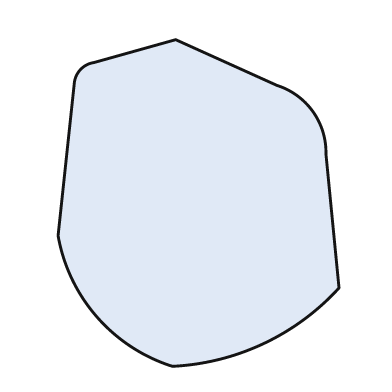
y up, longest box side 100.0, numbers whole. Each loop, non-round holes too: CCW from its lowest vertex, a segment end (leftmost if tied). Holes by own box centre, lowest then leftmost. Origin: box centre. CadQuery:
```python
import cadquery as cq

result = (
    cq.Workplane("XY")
    .moveTo(-8.0, -50.0)
    .threePointArc((20.0, -43.0), (43.0, -26.0))
    .lineTo(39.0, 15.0)
    .threePointArc((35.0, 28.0), (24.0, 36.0))
    .lineTo(-7.0, 50.0)
    .lineTo(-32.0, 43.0)
    .threePointArc((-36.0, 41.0), (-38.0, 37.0))
    .lineTo(-43.0, -10.0)
    .threePointArc((-31.0, -35.0), (-8.0, -50.0))
    .close()
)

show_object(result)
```